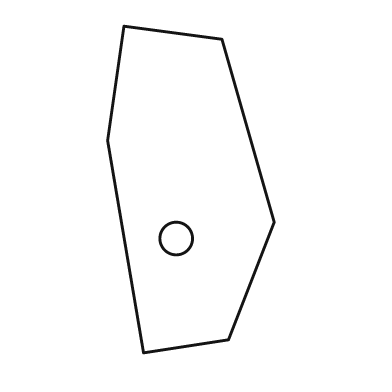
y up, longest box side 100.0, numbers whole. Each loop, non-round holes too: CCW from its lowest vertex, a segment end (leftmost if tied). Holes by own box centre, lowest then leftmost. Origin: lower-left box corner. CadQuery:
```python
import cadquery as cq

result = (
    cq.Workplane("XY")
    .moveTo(11.0, 0.0)
    .lineTo(37.0, 4.0)
    .lineTo(51.0, 40.0)
    .lineTo(35.0, 96.0)
    .lineTo(5.0, 100.0)
    .lineTo(0.0, 65.0)
    .close()
    .moveTo(21.0, 35.0)
    .circle(5.0)
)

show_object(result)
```